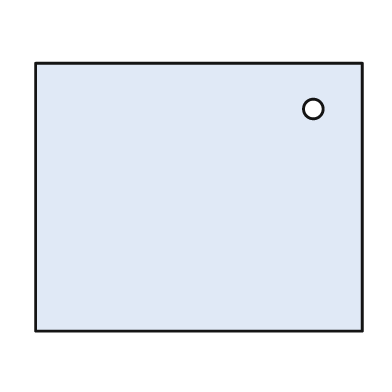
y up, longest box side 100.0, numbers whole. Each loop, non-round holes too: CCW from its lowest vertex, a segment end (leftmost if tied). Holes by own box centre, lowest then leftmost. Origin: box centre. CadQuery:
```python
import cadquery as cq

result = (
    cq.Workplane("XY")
    .moveTo(-50.0, -41.0)
    .lineTo(50.0, -41.0)
    .lineTo(50.0, 41.0)
    .lineTo(-50.0, 41.0)
    .close()
    .moveTo(35.0, 27.0)
    .circle(3.0)
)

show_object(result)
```